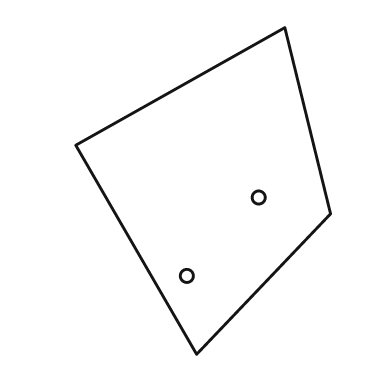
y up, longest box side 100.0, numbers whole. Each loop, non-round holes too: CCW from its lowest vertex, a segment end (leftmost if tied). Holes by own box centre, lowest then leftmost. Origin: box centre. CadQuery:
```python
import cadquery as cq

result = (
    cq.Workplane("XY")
    .moveTo(-2.0, -50.0)
    .lineTo(39.0, -7.0)
    .lineTo(25.0, 50.0)
    .lineTo(-39.0, 14.0)
    .close()
    .moveTo(-5.0, -26.0)
    .circle(2.0)
    .moveTo(17.0, -2.0)
    .circle(2.0)
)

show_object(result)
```